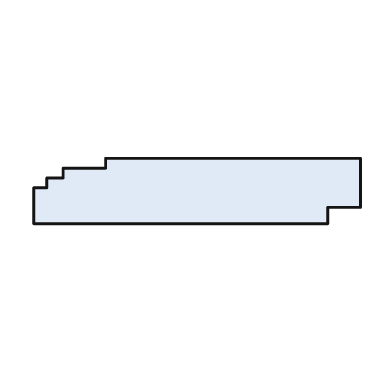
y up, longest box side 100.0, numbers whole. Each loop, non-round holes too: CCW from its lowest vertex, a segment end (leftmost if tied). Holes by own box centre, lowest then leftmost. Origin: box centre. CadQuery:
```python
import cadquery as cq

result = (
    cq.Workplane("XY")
    .moveTo(-50.0, -10.0)
    .lineTo(40.0, -10.0)
    .lineTo(40.0, -5.0)
    .lineTo(50.0, -5.0)
    .lineTo(50.0, 10.0)
    .lineTo(-28.0, 10.0)
    .lineTo(-28.0, 7.0)
    .lineTo(-41.0, 7.0)
    .lineTo(-41.0, 4.0)
    .lineTo(-46.0, 4.0)
    .lineTo(-46.0, 1.0)
    .lineTo(-50.0, 1.0)
    .close()
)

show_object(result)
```